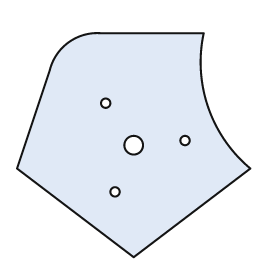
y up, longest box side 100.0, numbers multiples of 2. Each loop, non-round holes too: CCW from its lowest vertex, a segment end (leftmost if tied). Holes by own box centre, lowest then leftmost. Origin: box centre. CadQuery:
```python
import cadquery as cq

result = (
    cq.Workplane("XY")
    .moveTo(0.0, -48.0)
    .lineTo(50.0, -10.0)
    .threePointArc((32.0, 16.0), (30.0, 48.0))
    .lineTo(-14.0, 48.0)
    .threePointArc((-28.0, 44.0), (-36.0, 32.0))
    .lineTo(-50.0, -10.0)
    .close()
    .moveTo(-8.0, -20.0)
    .circle(2.0)
    .moveTo(0.0, 0.0)
    .circle(4.0)
    .moveTo(22.0, 2.0)
    .circle(2.0)
    .moveTo(-12.0, 18.0)
    .circle(2.0)
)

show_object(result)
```